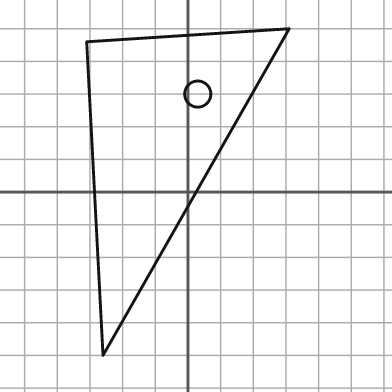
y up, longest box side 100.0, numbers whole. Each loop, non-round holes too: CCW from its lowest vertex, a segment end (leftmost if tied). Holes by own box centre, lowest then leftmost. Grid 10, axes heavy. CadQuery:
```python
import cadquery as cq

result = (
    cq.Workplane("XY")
    .moveTo(-26.0, -50.0)
    .lineTo(31.0, 50.0)
    .lineTo(-31.0, 46.0)
    .close()
    .moveTo(3.0, 30.0)
    .circle(4.0)
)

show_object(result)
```